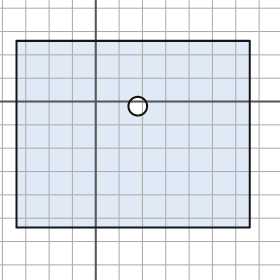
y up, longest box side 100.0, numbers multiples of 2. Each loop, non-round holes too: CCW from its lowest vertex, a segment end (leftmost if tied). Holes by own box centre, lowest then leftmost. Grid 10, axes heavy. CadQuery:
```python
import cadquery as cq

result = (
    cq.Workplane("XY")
    .moveTo(-34.0, -54.0)
    .lineTo(66.0, -54.0)
    .lineTo(66.0, 26.0)
    .lineTo(-34.0, 26.0)
    .close()
    .moveTo(18.0, -2.0)
    .circle(4.0)
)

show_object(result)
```